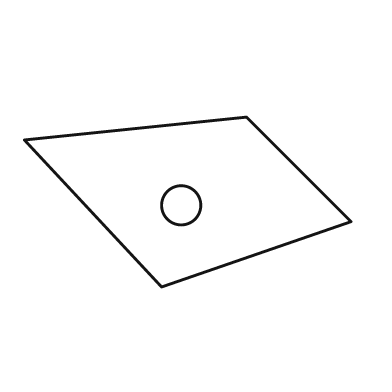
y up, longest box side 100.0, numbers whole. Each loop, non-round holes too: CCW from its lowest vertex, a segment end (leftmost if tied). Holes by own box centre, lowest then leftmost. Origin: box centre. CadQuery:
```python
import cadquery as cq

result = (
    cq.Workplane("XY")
    .moveTo(-8.0, -26.0)
    .lineTo(50.0, -6.0)
    .lineTo(18.0, 26.0)
    .lineTo(-50.0, 19.0)
    .close()
    .moveTo(-2.0, -1.0)
    .circle(6.0)
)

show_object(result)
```